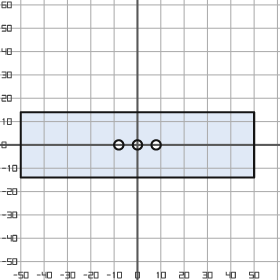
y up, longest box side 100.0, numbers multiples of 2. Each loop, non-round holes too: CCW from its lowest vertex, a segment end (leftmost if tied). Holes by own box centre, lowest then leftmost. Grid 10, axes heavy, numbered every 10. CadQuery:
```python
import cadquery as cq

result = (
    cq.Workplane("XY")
    .moveTo(-50.0, -14.0)
    .lineTo(50.0, -14.0)
    .lineTo(50.0, 14.0)
    .lineTo(-50.0, 14.0)
    .close()
    .moveTo(-8.0, 0.0)
    .circle(2.0)
    .moveTo(0.0, 0.0)
    .circle(2.0)
    .moveTo(8.0, 0.0)
    .circle(2.0)
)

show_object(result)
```